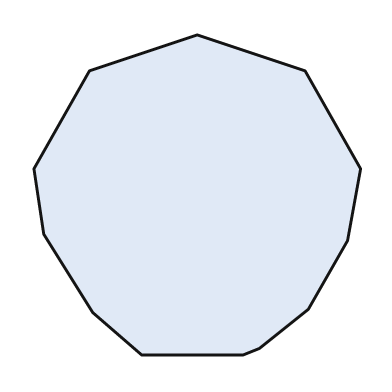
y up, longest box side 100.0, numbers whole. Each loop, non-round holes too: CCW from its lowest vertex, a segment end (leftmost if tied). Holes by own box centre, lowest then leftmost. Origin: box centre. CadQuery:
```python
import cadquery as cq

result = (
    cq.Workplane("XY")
    .moveTo(-17.0, -49.0)
    .lineTo(14.0, -49.0)
    .lineTo(19.0, -47.0)
    .lineTo(34.0, -35.0)
    .lineTo(46.0, -14.0)
    .lineTo(50.0, 8.0)
    .lineTo(33.0, 38.0)
    .lineTo(0.0, 49.0)
    .lineTo(-33.0, 38.0)
    .lineTo(-50.0, 8.0)
    .lineTo(-47.0, -12.0)
    .lineTo(-32.0, -36.0)
    .close()
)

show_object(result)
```